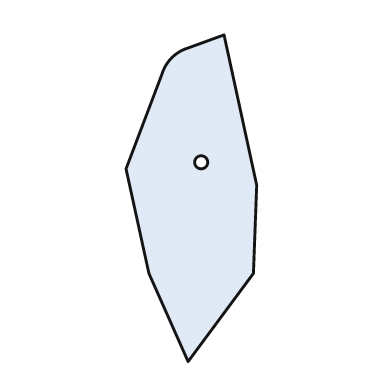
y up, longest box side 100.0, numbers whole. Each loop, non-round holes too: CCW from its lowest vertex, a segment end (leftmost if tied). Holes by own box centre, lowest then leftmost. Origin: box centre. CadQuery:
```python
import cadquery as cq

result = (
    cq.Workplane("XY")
    .moveTo(-1.0, -50.0)
    .lineTo(19.0, -23.0)
    .lineTo(20.0, 4.0)
    .lineTo(10.0, 50.0)
    .lineTo(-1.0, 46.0)
    .threePointArc((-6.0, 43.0), (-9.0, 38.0))
    .lineTo(-20.0, 9.0)
    .lineTo(-13.0, -23.0)
    .close()
    .moveTo(3.0, 11.0)
    .circle(2.0)
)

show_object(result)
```